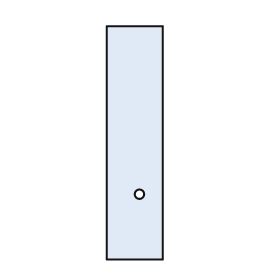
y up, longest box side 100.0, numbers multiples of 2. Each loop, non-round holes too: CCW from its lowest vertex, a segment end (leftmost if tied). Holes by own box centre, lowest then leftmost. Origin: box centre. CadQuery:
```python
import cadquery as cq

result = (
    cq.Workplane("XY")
    .moveTo(-12.0, -50.0)
    .lineTo(12.0, -50.0)
    .lineTo(12.0, 50.0)
    .lineTo(-12.0, 50.0)
    .close()
    .moveTo(2.0, -22.0)
    .circle(2.0)
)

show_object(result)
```